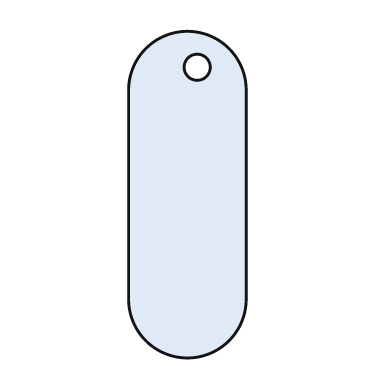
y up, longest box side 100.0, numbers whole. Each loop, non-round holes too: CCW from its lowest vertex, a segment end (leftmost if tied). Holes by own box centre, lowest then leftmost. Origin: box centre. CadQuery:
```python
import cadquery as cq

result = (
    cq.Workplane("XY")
    .moveTo(-18.0, -32.0)
    .threePointArc((0.0, -50.0), (18.0, -32.0))
    .lineTo(18.0, 32.0)
    .threePointArc((0.0, 50.0), (-18.0, 32.0))
    .close()
    .moveTo(3.0, 39.0)
    .circle(4.0)
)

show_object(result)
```